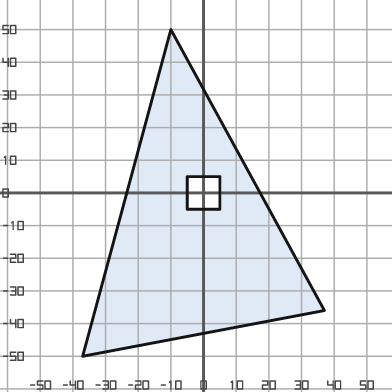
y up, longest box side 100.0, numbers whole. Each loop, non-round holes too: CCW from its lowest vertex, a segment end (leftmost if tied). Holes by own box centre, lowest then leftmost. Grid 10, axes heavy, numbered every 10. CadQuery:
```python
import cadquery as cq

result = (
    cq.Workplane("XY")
    .moveTo(-37.0, -50.0)
    .lineTo(37.0, -36.0)
    .lineTo(-10.0, 50.0)
    .close()
    .moveTo(-5.0, -5.0)
    .lineTo(5.0, -5.0)
    .lineTo(5.0, 5.0)
    .lineTo(-5.0, 5.0)
    .close()
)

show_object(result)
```